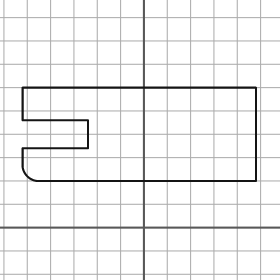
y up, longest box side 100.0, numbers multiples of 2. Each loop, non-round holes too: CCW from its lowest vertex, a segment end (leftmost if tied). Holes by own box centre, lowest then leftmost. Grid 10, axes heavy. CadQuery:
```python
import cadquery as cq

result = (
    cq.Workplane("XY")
    .moveTo(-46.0, 20.0)
    .lineTo(48.0, 20.0)
    .lineTo(48.0, 60.0)
    .lineTo(-52.0, 60.0)
    .lineTo(-52.0, 46.0)
    .lineTo(-24.0, 46.0)
    .lineTo(-24.0, 34.0)
    .lineTo(-52.0, 34.0)
    .lineTo(-52.0, 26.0)
    .threePointArc((-50.0, 22.0), (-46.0, 20.0))
    .close()
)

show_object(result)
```